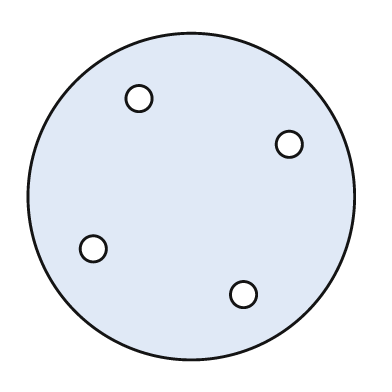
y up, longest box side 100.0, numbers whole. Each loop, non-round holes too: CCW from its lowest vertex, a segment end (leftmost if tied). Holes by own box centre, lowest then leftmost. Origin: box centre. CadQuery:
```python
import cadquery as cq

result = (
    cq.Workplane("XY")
    .moveTo(0.0, 0.0)
    .circle(50.0)
    .moveTo(16.0, -30.0)
    .circle(4.0)
    .moveTo(-30.0, -16.0)
    .circle(4.0)
    .moveTo(30.0, 16.0)
    .circle(4.0)
    .moveTo(-16.0, 30.0)
    .circle(4.0)
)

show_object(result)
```